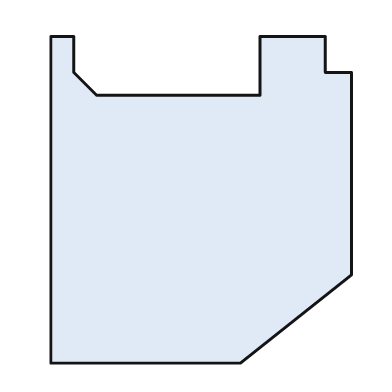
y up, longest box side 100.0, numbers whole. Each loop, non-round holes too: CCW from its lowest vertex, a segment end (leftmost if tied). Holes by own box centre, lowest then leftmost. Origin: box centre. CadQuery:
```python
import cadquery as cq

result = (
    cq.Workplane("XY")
    .moveTo(-46.0, -50.0)
    .lineTo(12.0, -50.0)
    .lineTo(46.0, -23.0)
    .lineTo(46.0, 39.0)
    .lineTo(38.0, 39.0)
    .lineTo(38.0, 50.0)
    .lineTo(18.0, 50.0)
    .lineTo(18.0, 32.0)
    .lineTo(-32.0, 32.0)
    .lineTo(-39.0, 39.0)
    .lineTo(-39.0, 50.0)
    .lineTo(-46.0, 50.0)
    .close()
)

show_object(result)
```